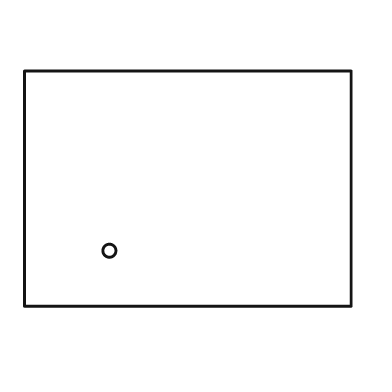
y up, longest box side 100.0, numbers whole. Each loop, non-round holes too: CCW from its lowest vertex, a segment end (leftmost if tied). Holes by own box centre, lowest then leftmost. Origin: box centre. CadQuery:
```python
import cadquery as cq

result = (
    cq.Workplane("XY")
    .moveTo(-50.0, -36.0)
    .lineTo(50.0, -36.0)
    .lineTo(50.0, 36.0)
    .lineTo(-50.0, 36.0)
    .close()
    .moveTo(-24.0, -19.0)
    .circle(2.0)
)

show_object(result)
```